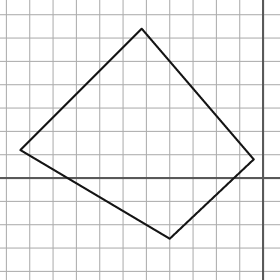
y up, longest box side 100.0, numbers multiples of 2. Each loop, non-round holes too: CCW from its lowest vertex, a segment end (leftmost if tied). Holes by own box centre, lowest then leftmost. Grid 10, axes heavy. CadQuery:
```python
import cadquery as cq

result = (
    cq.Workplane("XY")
    .moveTo(-40.0, -26.0)
    .lineTo(-4.0, 8.0)
    .lineTo(-52.0, 64.0)
    .lineTo(-104.0, 12.0)
    .close()
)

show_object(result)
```